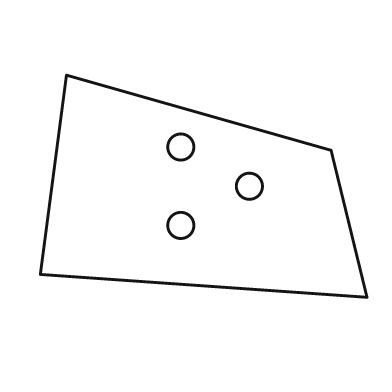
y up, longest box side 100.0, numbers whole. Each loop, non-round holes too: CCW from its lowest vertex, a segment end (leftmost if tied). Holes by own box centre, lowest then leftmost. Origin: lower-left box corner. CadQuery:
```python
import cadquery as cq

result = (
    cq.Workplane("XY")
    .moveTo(100.0, 0.0)
    .lineTo(89.0, 45.0)
    .lineTo(8.0, 68.0)
    .lineTo(0.0, 7.0)
    .close()
    .moveTo(43.0, 22.0)
    .circle(4.0)
    .moveTo(64.0, 34.0)
    .circle(4.0)
    .moveTo(43.0, 46.0)
    .circle(4.0)
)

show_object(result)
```